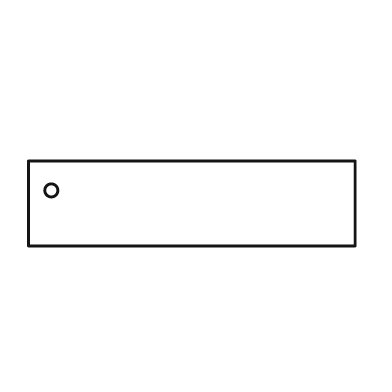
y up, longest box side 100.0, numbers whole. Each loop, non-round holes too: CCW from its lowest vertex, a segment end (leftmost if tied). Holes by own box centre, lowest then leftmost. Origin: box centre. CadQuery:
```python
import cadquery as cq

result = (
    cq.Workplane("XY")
    .moveTo(-50.0, -13.0)
    .lineTo(50.0, -13.0)
    .lineTo(50.0, 13.0)
    .lineTo(-50.0, 13.0)
    .close()
    .moveTo(-43.0, 4.0)
    .circle(2.0)
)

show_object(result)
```